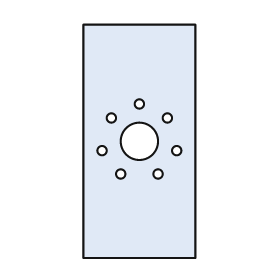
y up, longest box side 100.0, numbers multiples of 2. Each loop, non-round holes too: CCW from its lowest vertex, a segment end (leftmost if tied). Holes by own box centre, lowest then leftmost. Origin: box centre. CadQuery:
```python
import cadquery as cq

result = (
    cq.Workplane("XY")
    .moveTo(-24.0, -50.0)
    .lineTo(24.0, -50.0)
    .lineTo(24.0, 50.0)
    .lineTo(-24.0, 50.0)
    .close()
    .moveTo(-8.0, -14.0)
    .circle(2.0)
    .moveTo(8.0, -14.0)
    .circle(2.0)
    .moveTo(-16.0, -4.0)
    .circle(2.0)
    .moveTo(16.0, -4.0)
    .circle(2.0)
    .moveTo(0.0, 0.0)
    .circle(8.0)
    .moveTo(-12.0, 10.0)
    .circle(2.0)
    .moveTo(12.0, 10.0)
    .circle(2.0)
    .moveTo(0.0, 16.0)
    .circle(2.0)
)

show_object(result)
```